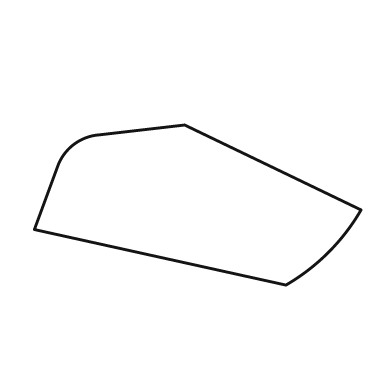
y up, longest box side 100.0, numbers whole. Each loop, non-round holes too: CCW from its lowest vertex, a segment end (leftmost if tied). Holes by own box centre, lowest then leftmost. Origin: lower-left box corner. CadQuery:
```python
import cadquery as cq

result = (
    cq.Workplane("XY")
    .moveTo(77.0, 0.0)
    .threePointArc((90.0, 10.0), (100.0, 23.0))
    .lineTo(46.0, 49.0)
    .lineTo(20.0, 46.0)
    .threePointArc((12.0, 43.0), (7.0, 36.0))
    .lineTo(0.0, 17.0)
    .close()
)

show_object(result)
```